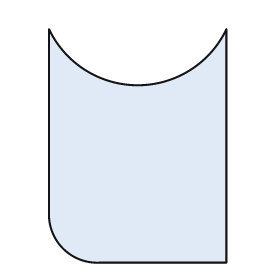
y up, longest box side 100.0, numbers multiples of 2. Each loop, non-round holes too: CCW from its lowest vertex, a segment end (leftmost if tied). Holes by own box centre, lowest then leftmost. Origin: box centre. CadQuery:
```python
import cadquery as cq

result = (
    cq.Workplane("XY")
    .moveTo(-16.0, -50.0)
    .lineTo(38.0, -50.0)
    .lineTo(38.0, 50.0)
    .threePointArc((0.0, 26.0), (-38.0, 50.0))
    .lineTo(-38.0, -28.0)
    .threePointArc((-32.0, -44.0), (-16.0, -50.0))
    .close()
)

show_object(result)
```